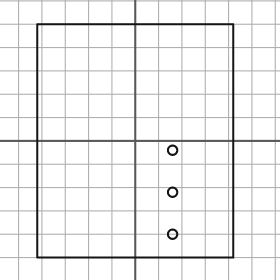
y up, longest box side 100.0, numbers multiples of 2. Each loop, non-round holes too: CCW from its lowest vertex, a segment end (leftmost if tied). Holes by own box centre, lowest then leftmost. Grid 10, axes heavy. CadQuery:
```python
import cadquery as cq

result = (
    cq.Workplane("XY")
    .moveTo(-42.0, -50.0)
    .lineTo(42.0, -50.0)
    .lineTo(42.0, 50.0)
    .lineTo(-42.0, 50.0)
    .close()
    .moveTo(16.0, -40.0)
    .circle(2.0)
    .moveTo(16.0, -22.0)
    .circle(2.0)
    .moveTo(16.0, -4.0)
    .circle(2.0)
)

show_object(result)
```